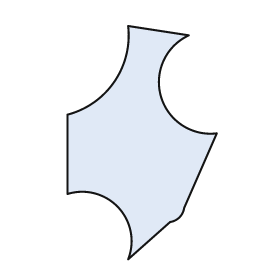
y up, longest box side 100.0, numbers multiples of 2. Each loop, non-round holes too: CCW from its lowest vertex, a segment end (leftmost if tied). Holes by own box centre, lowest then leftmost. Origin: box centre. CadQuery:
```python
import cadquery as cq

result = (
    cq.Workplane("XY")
    .moveTo(-6.0, -50.0)
    .lineTo(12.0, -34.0)
    .threePointArc((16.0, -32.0), (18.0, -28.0))
    .lineTo(32.0, 4.0)
    .threePointArc((8.0, 20.0), (20.0, 46.0))
    .lineTo(-6.0, 50.0)
    .threePointArc((-12.0, 26.0), (-32.0, 12.0))
    .lineTo(-32.0, -22.0)
    .threePointArc((-10.0, -28.0), (-6.0, -50.0))
    .close()
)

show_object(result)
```